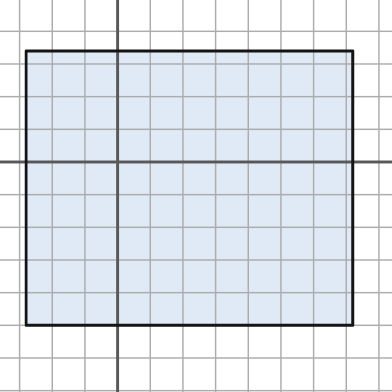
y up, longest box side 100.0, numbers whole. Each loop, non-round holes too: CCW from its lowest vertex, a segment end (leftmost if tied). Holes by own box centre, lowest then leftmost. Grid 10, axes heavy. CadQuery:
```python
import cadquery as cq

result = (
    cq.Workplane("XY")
    .moveTo(-28.0, -50.0)
    .lineTo(72.0, -50.0)
    .lineTo(72.0, 34.0)
    .lineTo(-28.0, 34.0)
    .close()
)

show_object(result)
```